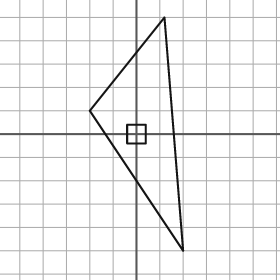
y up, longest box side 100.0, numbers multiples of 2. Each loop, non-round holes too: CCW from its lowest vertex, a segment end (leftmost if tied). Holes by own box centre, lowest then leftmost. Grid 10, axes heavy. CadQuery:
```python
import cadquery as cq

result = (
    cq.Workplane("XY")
    .moveTo(20.0, -50.0)
    .lineTo(12.0, 50.0)
    .lineTo(-20.0, 10.0)
    .close()
    .moveTo(-4.0, -4.0)
    .lineTo(4.0, -4.0)
    .lineTo(4.0, 4.0)
    .lineTo(-4.0, 4.0)
    .close()
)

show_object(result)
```